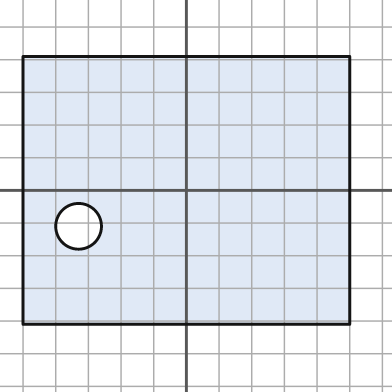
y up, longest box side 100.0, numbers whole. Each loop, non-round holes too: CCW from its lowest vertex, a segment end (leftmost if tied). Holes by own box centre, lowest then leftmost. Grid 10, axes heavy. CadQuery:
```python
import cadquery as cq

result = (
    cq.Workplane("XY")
    .moveTo(-50.0, -41.0)
    .lineTo(50.0, -41.0)
    .lineTo(50.0, 41.0)
    .lineTo(-50.0, 41.0)
    .close()
    .moveTo(-33.0, -11.0)
    .circle(7.0)
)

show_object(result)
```